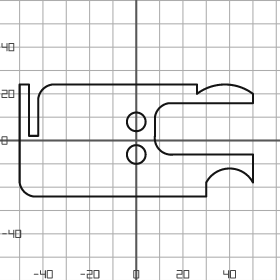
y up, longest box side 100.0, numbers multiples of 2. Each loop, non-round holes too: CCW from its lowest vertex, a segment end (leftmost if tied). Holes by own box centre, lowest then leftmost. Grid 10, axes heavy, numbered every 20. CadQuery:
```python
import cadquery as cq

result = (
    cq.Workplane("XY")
    .moveTo(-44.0, -24.0)
    .lineTo(30.0, -24.0)
    .lineTo(30.0, -18.0)
    .threePointArc((40.0, -12.0), (50.0, -18.0))
    .lineTo(50.0, -6.0)
    .lineTo(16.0, -6.0)
    .threePointArc((10.0, -4.0), (8.0, 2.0))
    .lineTo(8.0, 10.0)
    .threePointArc((10.0, 14.0), (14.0, 16.0))
    .lineTo(50.0, 16.0)
    .lineTo(50.0, 20.0)
    .threePointArc((38.0, 24.0), (26.0, 20.0))
    .lineTo(26.0, 24.0)
    .lineTo(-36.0, 24.0)
    .threePointArc((-40.0, 22.0), (-42.0, 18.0))
    .lineTo(-42.0, 2.0)
    .lineTo(-46.0, 2.0)
    .lineTo(-46.0, 24.0)
    .lineTo(-50.0, 24.0)
    .lineTo(-50.0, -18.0)
    .threePointArc((-48.0, -22.0), (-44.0, -24.0))
    .close()
    .moveTo(0.0, -6.0)
    .circle(4.0)
    .moveTo(0.0, 8.0)
    .circle(4.0)
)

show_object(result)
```